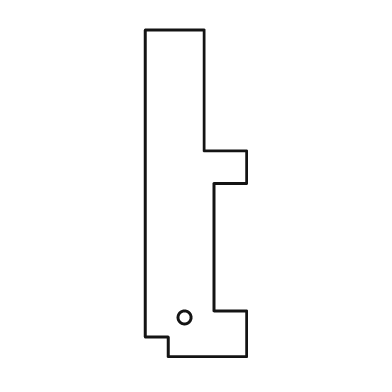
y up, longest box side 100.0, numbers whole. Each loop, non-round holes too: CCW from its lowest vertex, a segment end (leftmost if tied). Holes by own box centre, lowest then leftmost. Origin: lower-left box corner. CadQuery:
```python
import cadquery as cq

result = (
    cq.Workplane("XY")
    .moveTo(7.0, 0.0)
    .lineTo(31.0, 0.0)
    .lineTo(31.0, 14.0)
    .lineTo(21.0, 14.0)
    .lineTo(21.0, 53.0)
    .lineTo(31.0, 53.0)
    .lineTo(31.0, 63.0)
    .lineTo(18.0, 63.0)
    .lineTo(18.0, 100.0)
    .lineTo(0.0, 100.0)
    .lineTo(0.0, 6.0)
    .lineTo(7.0, 6.0)
    .close()
    .moveTo(12.0, 12.0)
    .circle(2.0)
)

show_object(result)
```